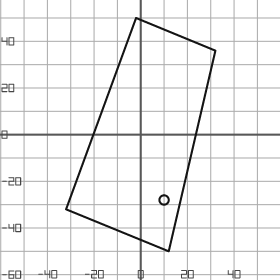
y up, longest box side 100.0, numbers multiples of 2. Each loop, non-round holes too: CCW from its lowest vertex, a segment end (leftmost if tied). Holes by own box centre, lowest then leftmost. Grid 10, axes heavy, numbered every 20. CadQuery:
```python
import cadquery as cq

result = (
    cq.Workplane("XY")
    .moveTo(12.0, -50.0)
    .lineTo(32.0, 36.0)
    .lineTo(-2.0, 50.0)
    .lineTo(-32.0, -32.0)
    .close()
    .moveTo(10.0, -28.0)
    .circle(2.0)
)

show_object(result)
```